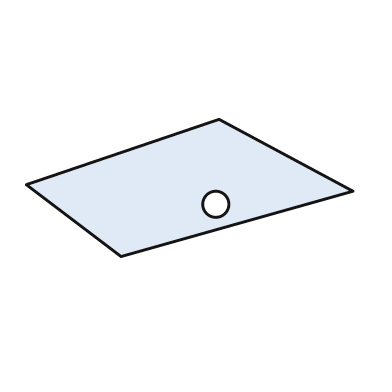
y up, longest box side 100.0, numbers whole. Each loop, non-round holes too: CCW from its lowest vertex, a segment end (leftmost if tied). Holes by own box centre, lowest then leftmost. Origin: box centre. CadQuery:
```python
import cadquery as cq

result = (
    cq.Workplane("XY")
    .moveTo(-21.0, -21.0)
    .lineTo(50.0, -1.0)
    .lineTo(9.0, 21.0)
    .lineTo(-50.0, 1.0)
    .close()
    .moveTo(8.0, -5.0)
    .circle(4.0)
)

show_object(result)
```